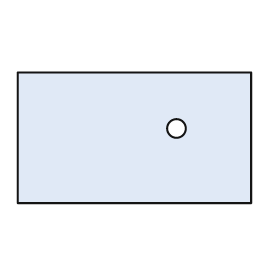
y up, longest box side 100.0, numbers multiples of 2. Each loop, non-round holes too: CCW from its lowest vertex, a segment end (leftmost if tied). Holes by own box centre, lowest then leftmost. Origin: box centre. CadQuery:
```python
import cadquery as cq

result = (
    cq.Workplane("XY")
    .moveTo(-50.0, -28.0)
    .lineTo(50.0, -28.0)
    .lineTo(50.0, 28.0)
    .lineTo(-50.0, 28.0)
    .close()
    .moveTo(18.0, 4.0)
    .circle(4.0)
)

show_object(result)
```